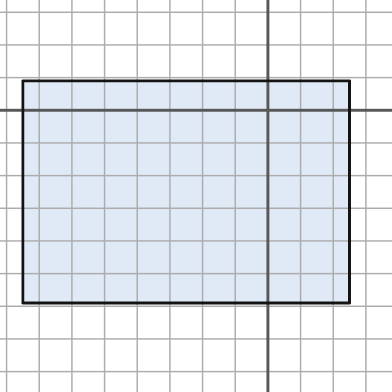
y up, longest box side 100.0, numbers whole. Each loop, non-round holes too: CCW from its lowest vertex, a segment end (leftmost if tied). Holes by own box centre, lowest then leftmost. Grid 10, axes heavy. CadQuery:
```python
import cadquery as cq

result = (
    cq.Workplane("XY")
    .moveTo(-75.0, -59.0)
    .lineTo(25.0, -59.0)
    .lineTo(25.0, 9.0)
    .lineTo(-75.0, 9.0)
    .close()
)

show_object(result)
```